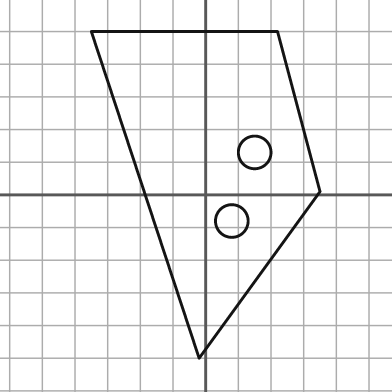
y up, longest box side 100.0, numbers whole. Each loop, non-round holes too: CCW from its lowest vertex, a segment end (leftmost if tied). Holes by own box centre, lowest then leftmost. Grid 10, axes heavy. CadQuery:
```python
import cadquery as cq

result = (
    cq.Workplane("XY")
    .moveTo(-2.0, -50.0)
    .lineTo(35.0, 1.0)
    .lineTo(22.0, 50.0)
    .lineTo(-35.0, 50.0)
    .close()
    .moveTo(8.0, -8.0)
    .circle(5.0)
    .moveTo(15.0, 13.0)
    .circle(5.0)
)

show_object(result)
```